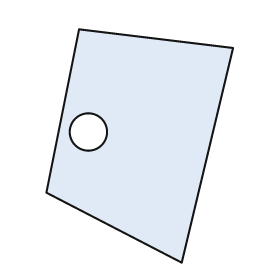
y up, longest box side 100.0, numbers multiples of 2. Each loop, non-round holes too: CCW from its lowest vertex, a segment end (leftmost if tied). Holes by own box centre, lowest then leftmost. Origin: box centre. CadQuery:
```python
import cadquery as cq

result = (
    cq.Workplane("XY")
    .moveTo(18.0, -50.0)
    .lineTo(40.0, 42.0)
    .lineTo(-26.0, 50.0)
    .lineTo(-40.0, -20.0)
    .close()
    .moveTo(-22.0, 6.0)
    .circle(8.0)
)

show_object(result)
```